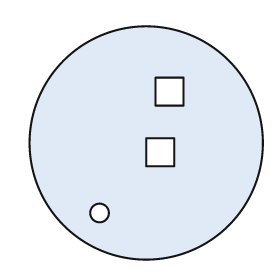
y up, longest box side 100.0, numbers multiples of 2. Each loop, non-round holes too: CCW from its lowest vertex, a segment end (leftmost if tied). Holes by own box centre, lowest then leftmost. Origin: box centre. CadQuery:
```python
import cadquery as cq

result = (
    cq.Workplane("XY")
    .moveTo(0.0, 0.0)
    .circle(50.0)
    .moveTo(-20.0, -30.0)
    .circle(4.0)
    .moveTo(0.0, -10.0)
    .lineTo(12.0, -10.0)
    .lineTo(12.0, 2.0)
    .lineTo(0.0, 2.0)
    .close()
    .moveTo(4.0, 16.0)
    .lineTo(16.0, 16.0)
    .lineTo(16.0, 28.0)
    .lineTo(4.0, 28.0)
    .close()
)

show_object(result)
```